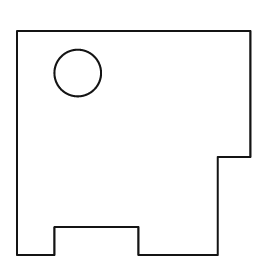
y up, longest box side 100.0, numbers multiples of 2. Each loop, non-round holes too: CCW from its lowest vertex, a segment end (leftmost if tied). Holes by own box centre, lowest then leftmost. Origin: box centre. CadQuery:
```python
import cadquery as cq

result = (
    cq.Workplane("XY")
    .moveTo(-50.0, -48.0)
    .lineTo(-34.0, -48.0)
    .lineTo(-34.0, -36.0)
    .lineTo(2.0, -36.0)
    .lineTo(2.0, -48.0)
    .lineTo(36.0, -48.0)
    .lineTo(36.0, -6.0)
    .lineTo(50.0, -6.0)
    .lineTo(50.0, 48.0)
    .lineTo(-50.0, 48.0)
    .close()
    .moveTo(-24.0, 30.0)
    .circle(10.0)
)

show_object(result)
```